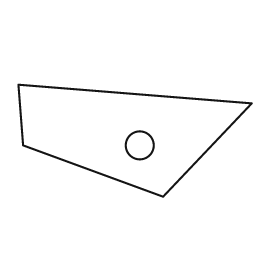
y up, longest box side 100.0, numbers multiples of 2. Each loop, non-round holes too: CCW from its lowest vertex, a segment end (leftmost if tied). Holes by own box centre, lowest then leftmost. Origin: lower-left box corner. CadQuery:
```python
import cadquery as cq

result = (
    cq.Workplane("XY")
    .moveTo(62.0, 0.0)
    .lineTo(100.0, 40.0)
    .lineTo(0.0, 48.0)
    .lineTo(2.0, 22.0)
    .close()
    .moveTo(52.0, 22.0)
    .circle(6.0)
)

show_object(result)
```